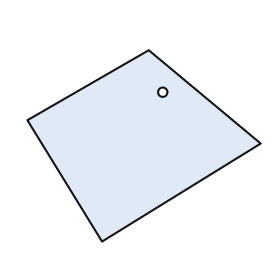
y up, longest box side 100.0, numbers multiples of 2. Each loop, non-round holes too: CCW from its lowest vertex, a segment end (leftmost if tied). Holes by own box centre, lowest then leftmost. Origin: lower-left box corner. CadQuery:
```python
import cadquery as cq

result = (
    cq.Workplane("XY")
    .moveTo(32.0, 0.0)
    .lineTo(100.0, 42.0)
    .lineTo(52.0, 82.0)
    .lineTo(0.0, 52.0)
    .close()
    .moveTo(58.0, 64.0)
    .circle(2.0)
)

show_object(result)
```